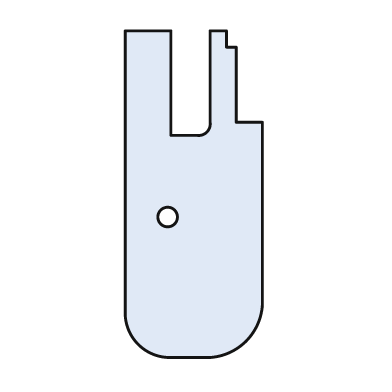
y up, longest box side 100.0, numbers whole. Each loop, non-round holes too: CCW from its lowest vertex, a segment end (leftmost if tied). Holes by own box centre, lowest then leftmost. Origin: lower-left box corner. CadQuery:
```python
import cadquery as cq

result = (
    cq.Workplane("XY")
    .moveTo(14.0, 0.0)
    .lineTo(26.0, 0.0)
    .threePointArc((37.0, 5.0), (42.0, 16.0))
    .lineTo(42.0, 72.0)
    .lineTo(34.0, 72.0)
    .lineTo(34.0, 95.0)
    .lineTo(31.0, 95.0)
    .lineTo(31.0, 100.0)
    .lineTo(26.0, 100.0)
    .lineTo(26.0, 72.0)
    .threePointArc((25.0, 69.0), (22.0, 68.0))
    .lineTo(14.0, 68.0)
    .lineTo(14.0, 100.0)
    .lineTo(0.0, 100.0)
    .lineTo(0.0, 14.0)
    .threePointArc((4.0, 4.0), (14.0, 0.0))
    .close()
    .moveTo(13.0, 43.0)
    .circle(3.0)
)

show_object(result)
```